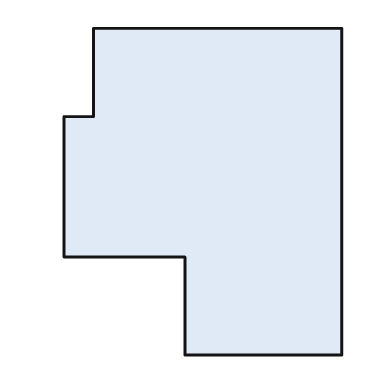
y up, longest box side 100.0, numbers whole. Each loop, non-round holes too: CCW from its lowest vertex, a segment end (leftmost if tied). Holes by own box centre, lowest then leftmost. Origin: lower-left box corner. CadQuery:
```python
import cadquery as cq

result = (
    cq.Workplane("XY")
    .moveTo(37.0, 0.0)
    .lineTo(85.0, 0.0)
    .lineTo(85.0, 100.0)
    .lineTo(9.0, 100.0)
    .lineTo(9.0, 73.0)
    .lineTo(0.0, 73.0)
    .lineTo(0.0, 30.0)
    .lineTo(37.0, 30.0)
    .close()
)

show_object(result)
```